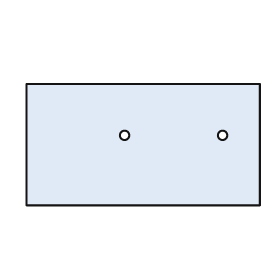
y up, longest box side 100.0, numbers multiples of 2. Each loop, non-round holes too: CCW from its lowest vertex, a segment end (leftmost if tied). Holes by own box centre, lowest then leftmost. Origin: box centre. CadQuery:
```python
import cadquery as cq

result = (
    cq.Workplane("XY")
    .moveTo(-50.0, -26.0)
    .lineTo(50.0, -26.0)
    .lineTo(50.0, 26.0)
    .lineTo(-50.0, 26.0)
    .close()
    .moveTo(-8.0, 4.0)
    .circle(2.0)
    .moveTo(34.0, 4.0)
    .circle(2.0)
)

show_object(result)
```